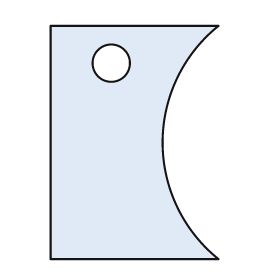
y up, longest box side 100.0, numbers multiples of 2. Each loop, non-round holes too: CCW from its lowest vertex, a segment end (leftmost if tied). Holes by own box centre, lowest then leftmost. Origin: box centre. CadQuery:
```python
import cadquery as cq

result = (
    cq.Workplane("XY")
    .moveTo(-36.0, -50.0)
    .lineTo(36.0, -50.0)
    .threePointArc((12.0, 0.0), (36.0, 50.0))
    .lineTo(-36.0, 50.0)
    .close()
    .moveTo(-10.0, 34.0)
    .circle(8.0)
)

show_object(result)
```